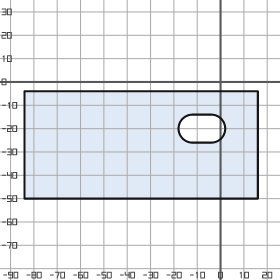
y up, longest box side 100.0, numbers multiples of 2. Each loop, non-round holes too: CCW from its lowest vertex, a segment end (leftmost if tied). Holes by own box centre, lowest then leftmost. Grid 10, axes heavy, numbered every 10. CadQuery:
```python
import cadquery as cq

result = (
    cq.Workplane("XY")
    .moveTo(-84.0, -50.0)
    .lineTo(16.0, -50.0)
    .lineTo(16.0, -4.0)
    .lineTo(-84.0, -4.0)
    .close()
    .moveTo(-12.0, -26.0)
    .lineTo(-4.0, -26.0)
    .threePointArc((2.0, -20.0), (-4.0, -14.0))
    .lineTo(-12.0, -14.0)
    .threePointArc((-18.0, -20.0), (-12.0, -26.0))
    .close()
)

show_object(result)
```